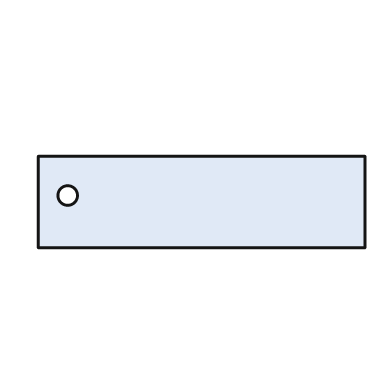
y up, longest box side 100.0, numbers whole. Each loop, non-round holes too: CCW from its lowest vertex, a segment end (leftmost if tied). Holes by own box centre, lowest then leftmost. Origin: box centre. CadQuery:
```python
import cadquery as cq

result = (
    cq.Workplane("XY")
    .moveTo(-50.0, -14.0)
    .lineTo(50.0, -14.0)
    .lineTo(50.0, 14.0)
    .lineTo(-50.0, 14.0)
    .close()
    .moveTo(-41.0, 2.0)
    .circle(3.0)
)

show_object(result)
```